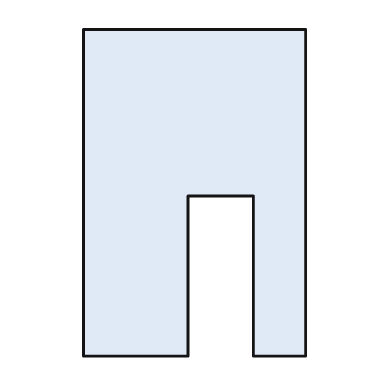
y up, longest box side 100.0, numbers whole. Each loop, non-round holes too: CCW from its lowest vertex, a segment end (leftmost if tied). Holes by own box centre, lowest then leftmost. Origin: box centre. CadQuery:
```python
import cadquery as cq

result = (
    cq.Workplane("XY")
    .moveTo(-34.0, -50.0)
    .lineTo(-2.0, -50.0)
    .lineTo(-2.0, -1.0)
    .lineTo(18.0, -1.0)
    .lineTo(18.0, -50.0)
    .lineTo(34.0, -50.0)
    .lineTo(34.0, 50.0)
    .lineTo(-34.0, 50.0)
    .close()
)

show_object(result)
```